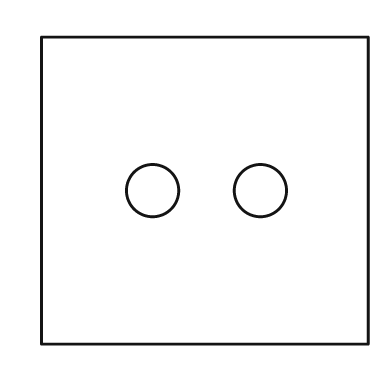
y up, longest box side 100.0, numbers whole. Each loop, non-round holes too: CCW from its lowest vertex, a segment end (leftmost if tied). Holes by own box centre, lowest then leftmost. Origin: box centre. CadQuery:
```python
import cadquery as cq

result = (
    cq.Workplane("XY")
    .moveTo(-50.0, -47.0)
    .lineTo(50.0, -47.0)
    .lineTo(50.0, 47.0)
    .lineTo(-50.0, 47.0)
    .close()
    .moveTo(-16.0, 0.0)
    .circle(8.0)
    .moveTo(17.0, 0.0)
    .circle(8.0)
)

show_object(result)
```